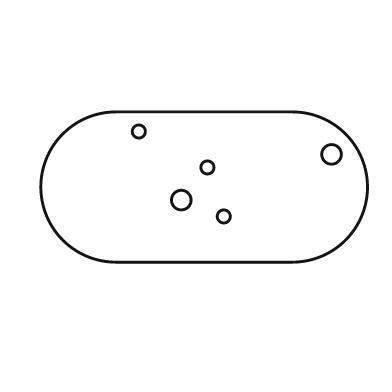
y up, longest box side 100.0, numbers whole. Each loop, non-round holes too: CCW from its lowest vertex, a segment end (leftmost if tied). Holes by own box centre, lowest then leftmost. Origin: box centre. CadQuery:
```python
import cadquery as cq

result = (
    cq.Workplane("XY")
    .moveTo(-27.0, -23.0)
    .lineTo(27.0, -23.0)
    .threePointArc((50.0, 0.0), (27.0, 23.0))
    .lineTo(-27.0, 23.0)
    .threePointArc((-50.0, 0.0), (-27.0, -23.0))
    .close()
    .moveTo(6.0, -9.0)
    .circle(2.0)
    .moveTo(-7.0, -4.0)
    .circle(3.0)
    .moveTo(1.0, 6.0)
    .circle(2.0)
    .moveTo(39.0, 10.0)
    .circle(3.0)
    .moveTo(-20.0, 17.0)
    .circle(2.0)
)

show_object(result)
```